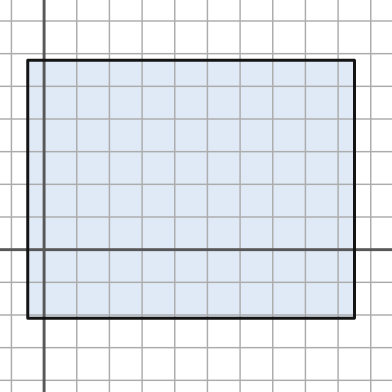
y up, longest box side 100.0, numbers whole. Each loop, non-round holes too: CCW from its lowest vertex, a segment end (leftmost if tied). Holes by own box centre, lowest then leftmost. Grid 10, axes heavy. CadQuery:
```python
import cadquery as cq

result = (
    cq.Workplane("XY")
    .moveTo(-5.0, -21.0)
    .lineTo(95.0, -21.0)
    .lineTo(95.0, 58.0)
    .lineTo(-5.0, 58.0)
    .close()
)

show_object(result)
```